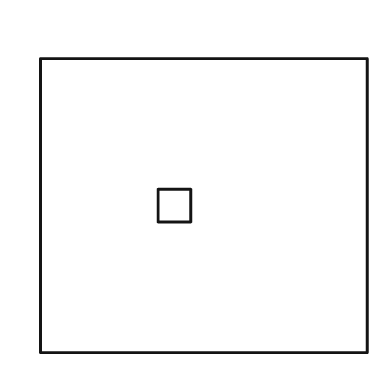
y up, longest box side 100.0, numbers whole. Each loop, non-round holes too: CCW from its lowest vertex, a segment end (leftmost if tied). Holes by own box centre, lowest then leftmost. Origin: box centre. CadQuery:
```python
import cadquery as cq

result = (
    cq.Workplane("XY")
    .moveTo(-50.0, -45.0)
    .lineTo(50.0, -45.0)
    .lineTo(50.0, 45.0)
    .lineTo(-50.0, 45.0)
    .close()
    .moveTo(-14.0, -5.0)
    .lineTo(-4.0, -5.0)
    .lineTo(-4.0, 5.0)
    .lineTo(-14.0, 5.0)
    .close()
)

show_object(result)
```